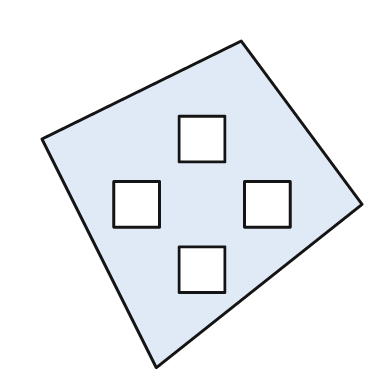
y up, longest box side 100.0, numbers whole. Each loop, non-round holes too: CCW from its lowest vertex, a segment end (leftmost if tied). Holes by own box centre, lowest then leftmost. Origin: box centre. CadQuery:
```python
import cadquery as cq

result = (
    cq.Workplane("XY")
    .moveTo(-14.0, -50.0)
    .lineTo(49.0, 0.0)
    .lineTo(12.0, 50.0)
    .lineTo(-49.0, 20.0)
    .close()
    .moveTo(-7.0, -27.0)
    .lineTo(7.0, -27.0)
    .lineTo(7.0, -13.0)
    .lineTo(-7.0, -13.0)
    .close()
    .moveTo(-27.0, -7.0)
    .lineTo(-13.0, -7.0)
    .lineTo(-13.0, 7.0)
    .lineTo(-27.0, 7.0)
    .close()
    .moveTo(13.0, -7.0)
    .lineTo(27.0, -7.0)
    .lineTo(27.0, 7.0)
    .lineTo(13.0, 7.0)
    .close()
    .moveTo(-7.0, 13.0)
    .lineTo(7.0, 13.0)
    .lineTo(7.0, 27.0)
    .lineTo(-7.0, 27.0)
    .close()
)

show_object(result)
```